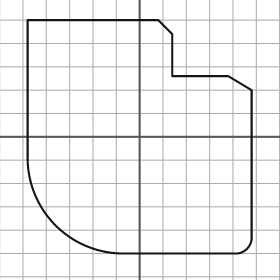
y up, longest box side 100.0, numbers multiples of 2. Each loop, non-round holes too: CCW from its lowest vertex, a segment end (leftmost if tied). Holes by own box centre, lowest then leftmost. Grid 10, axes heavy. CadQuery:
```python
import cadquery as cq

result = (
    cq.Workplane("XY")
    .moveTo(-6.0, -50.0)
    .lineTo(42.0, -50.0)
    .threePointArc((46.0, -48.0), (48.0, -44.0))
    .lineTo(48.0, 20.0)
    .lineTo(38.0, 26.0)
    .lineTo(14.0, 26.0)
    .lineTo(14.0, 44.0)
    .lineTo(8.0, 50.0)
    .lineTo(-48.0, 50.0)
    .lineTo(-48.0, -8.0)
    .threePointArc((-36.0, -38.0), (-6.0, -50.0))
    .close()
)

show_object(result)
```